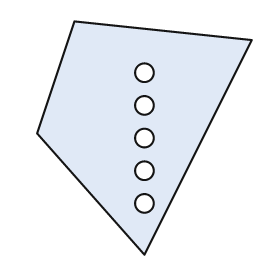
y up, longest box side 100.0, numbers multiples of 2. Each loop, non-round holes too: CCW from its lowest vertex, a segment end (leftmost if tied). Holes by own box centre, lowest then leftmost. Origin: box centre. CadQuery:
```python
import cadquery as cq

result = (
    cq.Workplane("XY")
    .moveTo(0.0, -50.0)
    .lineTo(46.0, 42.0)
    .lineTo(-30.0, 50.0)
    .lineTo(-46.0, 2.0)
    .close()
    .moveTo(0.0, -28.0)
    .circle(4.0)
    .moveTo(0.0, -14.0)
    .circle(4.0)
    .moveTo(0.0, 0.0)
    .circle(4.0)
    .moveTo(0.0, 14.0)
    .circle(4.0)
    .moveTo(0.0, 28.0)
    .circle(4.0)
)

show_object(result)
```